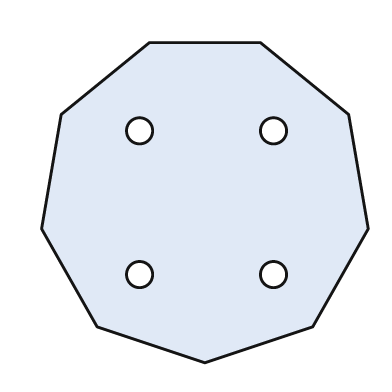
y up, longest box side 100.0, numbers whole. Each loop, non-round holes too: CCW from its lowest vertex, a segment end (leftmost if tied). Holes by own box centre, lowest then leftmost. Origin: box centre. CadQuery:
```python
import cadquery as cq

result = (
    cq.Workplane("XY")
    .moveTo(0.0, -49.0)
    .lineTo(33.0, -38.0)
    .lineTo(50.0, -8.0)
    .lineTo(44.0, 27.0)
    .lineTo(17.0, 49.0)
    .lineTo(-17.0, 49.0)
    .lineTo(-44.0, 27.0)
    .lineTo(-50.0, -8.0)
    .lineTo(-33.0, -38.0)
    .close()
    .moveTo(-20.0, -22.0)
    .circle(4.0)
    .moveTo(21.0, -22.0)
    .circle(4.0)
    .moveTo(-20.0, 22.0)
    .circle(4.0)
    .moveTo(21.0, 22.0)
    .circle(4.0)
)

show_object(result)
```